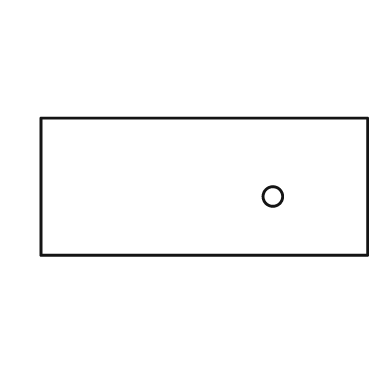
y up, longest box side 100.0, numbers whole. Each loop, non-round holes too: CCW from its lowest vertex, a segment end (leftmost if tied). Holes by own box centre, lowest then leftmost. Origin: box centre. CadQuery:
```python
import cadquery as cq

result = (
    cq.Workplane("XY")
    .moveTo(-50.0, -21.0)
    .lineTo(50.0, -21.0)
    .lineTo(50.0, 21.0)
    .lineTo(-50.0, 21.0)
    .close()
    .moveTo(21.0, -3.0)
    .circle(3.0)
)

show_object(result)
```